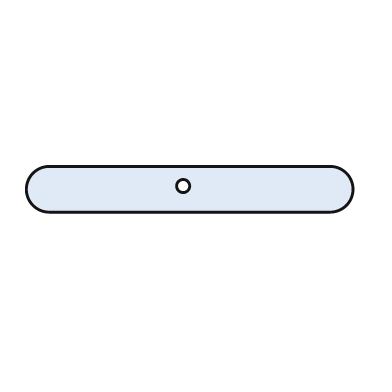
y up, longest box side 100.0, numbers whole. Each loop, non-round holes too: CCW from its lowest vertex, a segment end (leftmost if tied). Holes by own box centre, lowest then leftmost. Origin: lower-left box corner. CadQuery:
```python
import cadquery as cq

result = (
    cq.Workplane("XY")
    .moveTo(7.0, 0.0)
    .lineTo(93.0, 0.0)
    .threePointArc((100.0, 7.0), (93.0, 14.0))
    .lineTo(7.0, 14.0)
    .threePointArc((0.0, 7.0), (7.0, 0.0))
    .close()
    .moveTo(48.0, 8.0)
    .circle(2.0)
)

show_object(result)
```